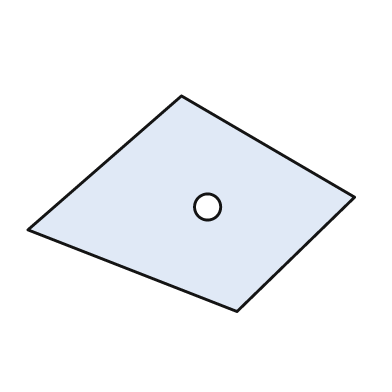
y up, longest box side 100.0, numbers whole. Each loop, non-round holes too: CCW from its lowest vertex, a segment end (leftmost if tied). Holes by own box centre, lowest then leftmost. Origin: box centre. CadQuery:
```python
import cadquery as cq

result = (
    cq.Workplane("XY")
    .moveTo(14.0, -33.0)
    .lineTo(50.0, 2.0)
    .lineTo(-3.0, 33.0)
    .lineTo(-50.0, -8.0)
    .close()
    .moveTo(5.0, -1.0)
    .circle(4.0)
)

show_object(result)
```